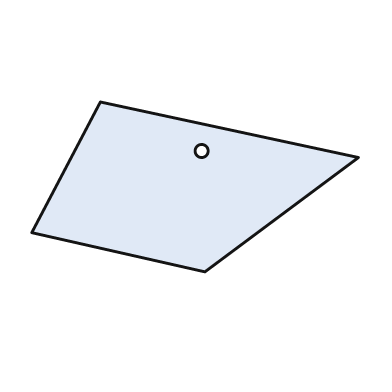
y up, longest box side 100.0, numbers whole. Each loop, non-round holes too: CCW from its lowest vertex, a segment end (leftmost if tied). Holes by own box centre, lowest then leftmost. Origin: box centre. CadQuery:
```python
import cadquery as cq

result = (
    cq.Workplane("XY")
    .moveTo(3.0, -26.0)
    .lineTo(50.0, 9.0)
    .lineTo(-29.0, 26.0)
    .lineTo(-50.0, -14.0)
    .close()
    .moveTo(2.0, 11.0)
    .circle(2.0)
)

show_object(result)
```